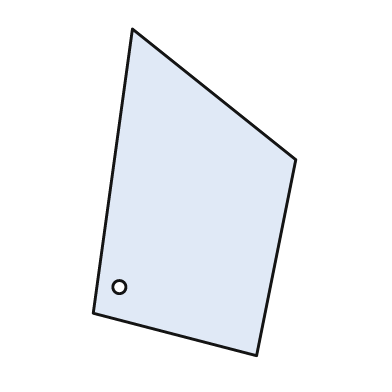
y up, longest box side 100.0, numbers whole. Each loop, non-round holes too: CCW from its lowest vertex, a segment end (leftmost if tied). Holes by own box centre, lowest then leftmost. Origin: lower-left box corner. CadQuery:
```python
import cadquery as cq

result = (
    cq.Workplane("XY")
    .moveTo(50.0, 0.0)
    .lineTo(62.0, 60.0)
    .lineTo(12.0, 100.0)
    .lineTo(0.0, 13.0)
    .close()
    .moveTo(8.0, 21.0)
    .circle(2.0)
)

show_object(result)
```